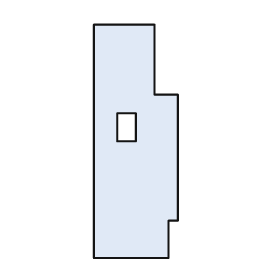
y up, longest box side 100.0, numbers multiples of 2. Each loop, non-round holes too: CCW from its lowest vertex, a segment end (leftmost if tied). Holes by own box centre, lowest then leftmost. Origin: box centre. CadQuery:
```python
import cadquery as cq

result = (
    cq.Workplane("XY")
    .moveTo(-18.0, -50.0)
    .lineTo(14.0, -50.0)
    .lineTo(14.0, -34.0)
    .lineTo(18.0, -34.0)
    .lineTo(18.0, 20.0)
    .lineTo(8.0, 20.0)
    .lineTo(8.0, 50.0)
    .lineTo(-18.0, 50.0)
    .close()
    .moveTo(-8.0, 0.0)
    .lineTo(0.0, 0.0)
    .lineTo(0.0, 12.0)
    .lineTo(-8.0, 12.0)
    .close()
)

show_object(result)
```